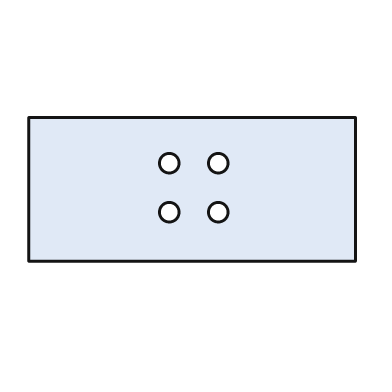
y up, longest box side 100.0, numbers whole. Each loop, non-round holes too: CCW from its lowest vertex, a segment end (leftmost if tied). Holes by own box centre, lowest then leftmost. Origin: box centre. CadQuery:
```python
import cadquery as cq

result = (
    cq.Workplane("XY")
    .moveTo(-50.0, -22.0)
    .lineTo(50.0, -22.0)
    .lineTo(50.0, 22.0)
    .lineTo(-50.0, 22.0)
    .close()
    .moveTo(-7.0, -7.0)
    .circle(3.0)
    .moveTo(8.0, -7.0)
    .circle(3.0)
    .moveTo(-7.0, 8.0)
    .circle(3.0)
    .moveTo(8.0, 8.0)
    .circle(3.0)
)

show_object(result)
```